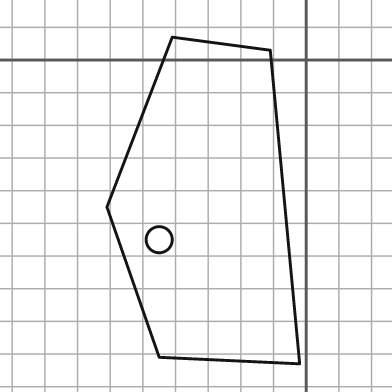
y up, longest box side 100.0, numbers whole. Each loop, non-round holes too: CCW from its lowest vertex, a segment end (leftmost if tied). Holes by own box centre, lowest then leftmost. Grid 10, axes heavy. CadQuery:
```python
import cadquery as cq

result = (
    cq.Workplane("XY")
    .moveTo(-2.0, -93.0)
    .lineTo(-11.0, 3.0)
    .lineTo(-41.0, 7.0)
    .lineTo(-61.0, -45.0)
    .lineTo(-45.0, -91.0)
    .close()
    .moveTo(-45.0, -55.0)
    .circle(4.0)
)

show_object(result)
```